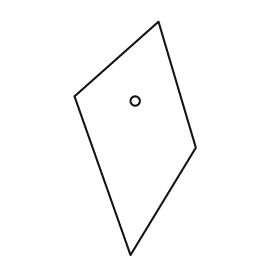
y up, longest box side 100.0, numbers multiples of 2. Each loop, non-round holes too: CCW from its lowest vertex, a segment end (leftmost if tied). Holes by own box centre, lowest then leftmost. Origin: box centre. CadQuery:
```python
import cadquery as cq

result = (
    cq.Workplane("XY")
    .moveTo(-2.0, -50.0)
    .lineTo(26.0, -4.0)
    .lineTo(10.0, 50.0)
    .lineTo(-26.0, 18.0)
    .close()
    .moveTo(0.0, 16.0)
    .circle(2.0)
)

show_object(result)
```